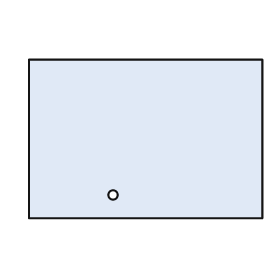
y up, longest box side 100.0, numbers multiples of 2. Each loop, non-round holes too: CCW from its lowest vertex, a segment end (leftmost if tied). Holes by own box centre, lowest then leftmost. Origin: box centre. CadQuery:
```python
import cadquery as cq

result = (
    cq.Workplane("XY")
    .moveTo(-50.0, -34.0)
    .lineTo(50.0, -34.0)
    .lineTo(50.0, 34.0)
    .lineTo(-50.0, 34.0)
    .close()
    .moveTo(-14.0, -24.0)
    .circle(2.0)
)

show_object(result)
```